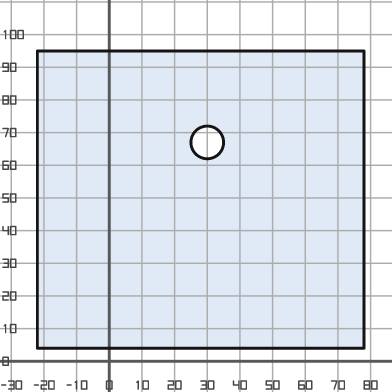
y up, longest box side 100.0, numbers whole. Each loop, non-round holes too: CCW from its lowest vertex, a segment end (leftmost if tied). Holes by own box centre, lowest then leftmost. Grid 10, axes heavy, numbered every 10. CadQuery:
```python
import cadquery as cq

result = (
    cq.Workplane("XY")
    .moveTo(-22.0, 4.0)
    .lineTo(78.0, 4.0)
    .lineTo(78.0, 95.0)
    .lineTo(-22.0, 95.0)
    .close()
    .moveTo(30.0, 67.0)
    .circle(5.0)
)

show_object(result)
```